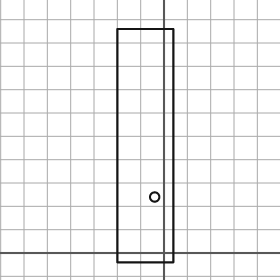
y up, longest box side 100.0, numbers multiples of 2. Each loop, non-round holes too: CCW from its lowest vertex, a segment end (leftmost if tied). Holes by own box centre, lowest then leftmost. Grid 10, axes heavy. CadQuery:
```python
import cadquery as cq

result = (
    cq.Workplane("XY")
    .moveTo(-20.0, -4.0)
    .lineTo(4.0, -4.0)
    .lineTo(4.0, 96.0)
    .lineTo(-20.0, 96.0)
    .close()
    .moveTo(-4.0, 24.0)
    .circle(2.0)
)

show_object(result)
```